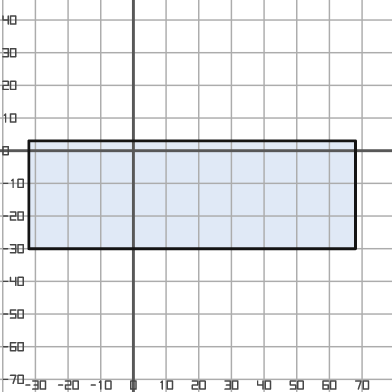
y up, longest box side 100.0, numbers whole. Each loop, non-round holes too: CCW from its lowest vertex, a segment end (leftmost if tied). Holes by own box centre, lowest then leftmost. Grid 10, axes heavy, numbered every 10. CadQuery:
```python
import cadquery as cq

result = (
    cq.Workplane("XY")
    .moveTo(-32.0, -30.0)
    .lineTo(68.0, -30.0)
    .lineTo(68.0, 3.0)
    .lineTo(-32.0, 3.0)
    .close()
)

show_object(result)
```